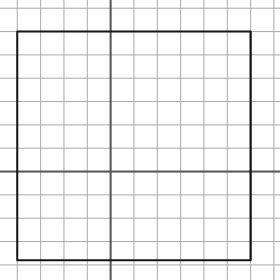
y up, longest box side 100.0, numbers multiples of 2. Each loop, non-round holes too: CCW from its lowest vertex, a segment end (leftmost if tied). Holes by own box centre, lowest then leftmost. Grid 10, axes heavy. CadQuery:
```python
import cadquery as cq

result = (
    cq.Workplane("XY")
    .moveTo(-40.0, -38.0)
    .lineTo(60.0, -38.0)
    .lineTo(60.0, 60.0)
    .lineTo(-40.0, 60.0)
    .close()
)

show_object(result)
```